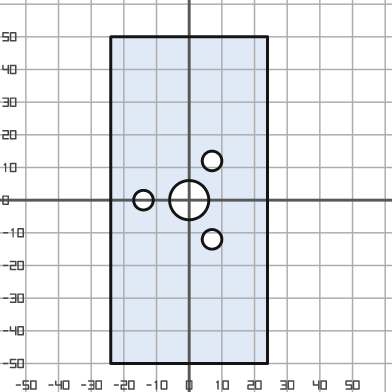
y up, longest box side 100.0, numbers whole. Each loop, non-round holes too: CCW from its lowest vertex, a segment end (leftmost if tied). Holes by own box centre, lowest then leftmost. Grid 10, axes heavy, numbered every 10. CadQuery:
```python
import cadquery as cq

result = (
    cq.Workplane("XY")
    .moveTo(-24.0, -50.0)
    .lineTo(24.0, -50.0)
    .lineTo(24.0, 50.0)
    .lineTo(-24.0, 50.0)
    .close()
    .moveTo(7.0, -12.0)
    .circle(3.0)
    .moveTo(-14.0, 0.0)
    .circle(3.0)
    .moveTo(0.0, 0.0)
    .circle(6.0)
    .moveTo(7.0, 12.0)
    .circle(3.0)
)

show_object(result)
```